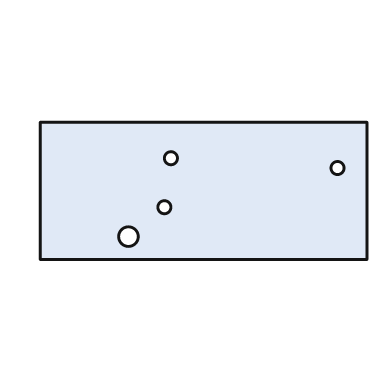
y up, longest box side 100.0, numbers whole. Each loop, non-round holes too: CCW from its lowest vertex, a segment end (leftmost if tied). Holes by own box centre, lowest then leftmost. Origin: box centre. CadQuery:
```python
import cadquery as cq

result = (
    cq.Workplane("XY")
    .moveTo(-50.0, -21.0)
    .lineTo(50.0, -21.0)
    .lineTo(50.0, 21.0)
    .lineTo(-50.0, 21.0)
    .close()
    .moveTo(-23.0, -14.0)
    .circle(3.0)
    .moveTo(-12.0, -5.0)
    .circle(2.0)
    .moveTo(41.0, 7.0)
    .circle(2.0)
    .moveTo(-10.0, 10.0)
    .circle(2.0)
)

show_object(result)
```